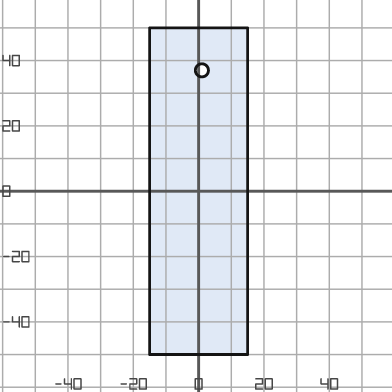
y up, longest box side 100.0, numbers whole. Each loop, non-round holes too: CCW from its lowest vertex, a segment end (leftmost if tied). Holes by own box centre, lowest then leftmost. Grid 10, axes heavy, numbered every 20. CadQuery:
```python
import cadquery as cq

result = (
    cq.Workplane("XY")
    .moveTo(-15.0, -50.0)
    .lineTo(15.0, -50.0)
    .lineTo(15.0, 50.0)
    .lineTo(-15.0, 50.0)
    .close()
    .moveTo(1.0, 37.0)
    .circle(2.0)
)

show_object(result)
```